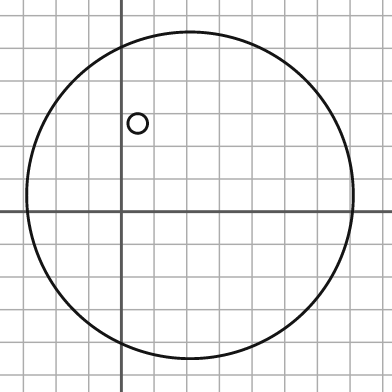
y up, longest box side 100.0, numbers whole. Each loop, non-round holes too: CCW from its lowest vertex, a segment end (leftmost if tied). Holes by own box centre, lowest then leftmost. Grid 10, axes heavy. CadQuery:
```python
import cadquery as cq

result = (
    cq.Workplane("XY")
    .moveTo(21.0, 5.0)
    .circle(50.0)
    .moveTo(5.0, 27.0)
    .circle(3.0)
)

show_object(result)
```